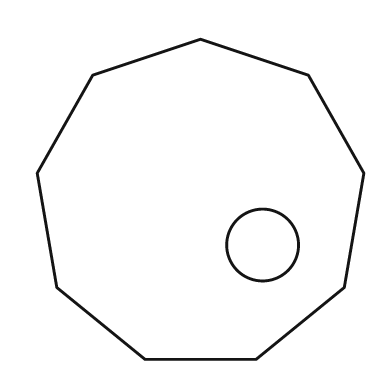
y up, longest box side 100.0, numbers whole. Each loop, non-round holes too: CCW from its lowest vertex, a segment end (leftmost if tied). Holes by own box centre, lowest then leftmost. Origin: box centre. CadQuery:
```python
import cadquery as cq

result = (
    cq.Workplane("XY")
    .moveTo(-17.0, -49.0)
    .lineTo(17.0, -49.0)
    .lineTo(44.0, -27.0)
    .lineTo(50.0, 8.0)
    .lineTo(33.0, 38.0)
    .lineTo(0.0, 49.0)
    .lineTo(-33.0, 38.0)
    .lineTo(-50.0, 8.0)
    .lineTo(-44.0, -27.0)
    .close()
    .moveTo(19.0, -14.0)
    .circle(11.0)
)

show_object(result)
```